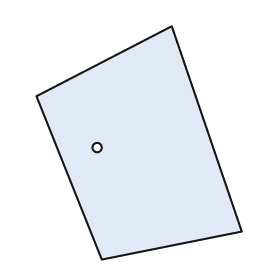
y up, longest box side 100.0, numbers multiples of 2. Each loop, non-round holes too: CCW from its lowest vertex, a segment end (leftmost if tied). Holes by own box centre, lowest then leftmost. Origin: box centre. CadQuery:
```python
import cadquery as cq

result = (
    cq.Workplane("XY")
    .moveTo(-16.0, -50.0)
    .lineTo(44.0, -38.0)
    .lineTo(14.0, 50.0)
    .lineTo(-44.0, 20.0)
    .close()
    .moveTo(-18.0, -2.0)
    .circle(2.0)
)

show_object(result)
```